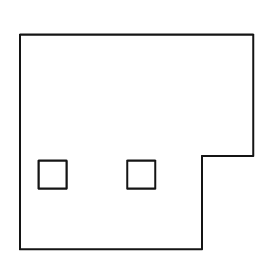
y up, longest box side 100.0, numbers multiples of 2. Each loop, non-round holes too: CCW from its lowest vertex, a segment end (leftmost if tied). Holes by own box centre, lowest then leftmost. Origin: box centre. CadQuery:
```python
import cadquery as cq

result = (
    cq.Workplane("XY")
    .moveTo(-50.0, -46.0)
    .lineTo(28.0, -46.0)
    .lineTo(28.0, -6.0)
    .lineTo(50.0, -6.0)
    .lineTo(50.0, 46.0)
    .lineTo(-50.0, 46.0)
    .close()
    .moveTo(-42.0, -20.0)
    .lineTo(-30.0, -20.0)
    .lineTo(-30.0, -8.0)
    .lineTo(-42.0, -8.0)
    .close()
    .moveTo(-4.0, -20.0)
    .lineTo(8.0, -20.0)
    .lineTo(8.0, -8.0)
    .lineTo(-4.0, -8.0)
    .close()
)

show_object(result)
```